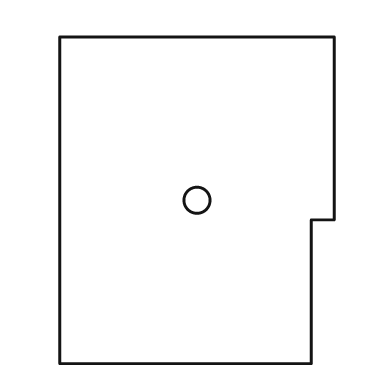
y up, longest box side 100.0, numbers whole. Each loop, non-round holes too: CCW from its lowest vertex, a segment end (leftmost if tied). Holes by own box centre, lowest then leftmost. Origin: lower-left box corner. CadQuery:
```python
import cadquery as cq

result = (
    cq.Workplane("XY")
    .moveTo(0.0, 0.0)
    .lineTo(77.0, 0.0)
    .lineTo(77.0, 44.0)
    .lineTo(84.0, 44.0)
    .lineTo(84.0, 100.0)
    .lineTo(0.0, 100.0)
    .close()
    .moveTo(42.0, 50.0)
    .circle(4.0)
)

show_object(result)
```